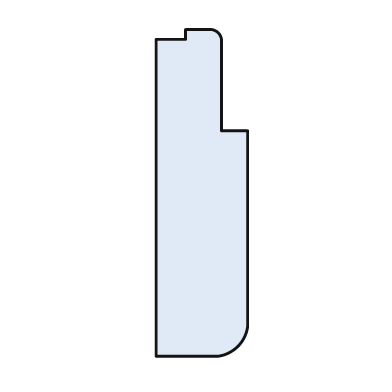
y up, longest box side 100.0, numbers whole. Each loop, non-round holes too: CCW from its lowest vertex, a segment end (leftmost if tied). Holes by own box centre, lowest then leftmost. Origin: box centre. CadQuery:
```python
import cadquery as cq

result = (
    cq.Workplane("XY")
    .moveTo(-14.0, -50.0)
    .lineTo(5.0, -50.0)
    .threePointArc((11.0, -47.0), (14.0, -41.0))
    .lineTo(14.0, 19.0)
    .lineTo(6.0, 19.0)
    .lineTo(6.0, 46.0)
    .threePointArc((5.0, 49.0), (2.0, 50.0))
    .lineTo(-5.0, 50.0)
    .lineTo(-5.0, 47.0)
    .lineTo(-14.0, 47.0)
    .close()
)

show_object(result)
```